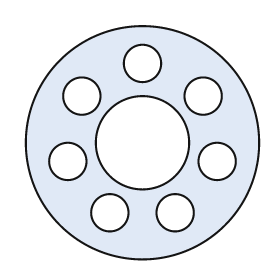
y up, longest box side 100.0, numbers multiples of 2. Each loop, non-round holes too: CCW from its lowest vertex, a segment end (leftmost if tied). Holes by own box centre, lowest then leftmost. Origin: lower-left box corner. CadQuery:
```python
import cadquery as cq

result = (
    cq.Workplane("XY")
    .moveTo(50.0, 50.0)
    .circle(50.0)
    .moveTo(36.0, 20.0)
    .circle(8.0)
    .moveTo(64.0, 20.0)
    .circle(8.0)
    .moveTo(18.0, 42.0)
    .circle(8.0)
    .moveTo(82.0, 42.0)
    .circle(8.0)
    .moveTo(50.0, 50.0)
    .circle(20.0)
    .moveTo(24.0, 70.0)
    .circle(8.0)
    .moveTo(76.0, 70.0)
    .circle(8.0)
    .moveTo(50.0, 84.0)
    .circle(8.0)
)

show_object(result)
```